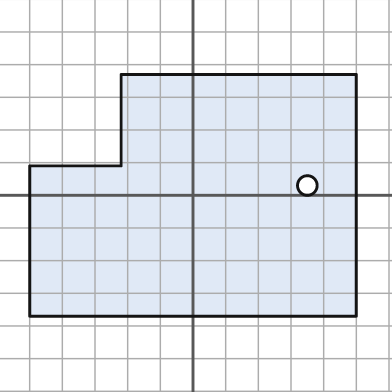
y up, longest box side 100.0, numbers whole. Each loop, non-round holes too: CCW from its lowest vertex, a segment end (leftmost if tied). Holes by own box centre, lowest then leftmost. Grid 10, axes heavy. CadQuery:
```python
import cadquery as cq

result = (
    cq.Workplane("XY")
    .moveTo(-50.0, -37.0)
    .lineTo(50.0, -37.0)
    .lineTo(50.0, 37.0)
    .lineTo(-22.0, 37.0)
    .lineTo(-22.0, 9.0)
    .lineTo(-50.0, 9.0)
    .close()
    .moveTo(35.0, 3.0)
    .circle(3.0)
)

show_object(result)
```